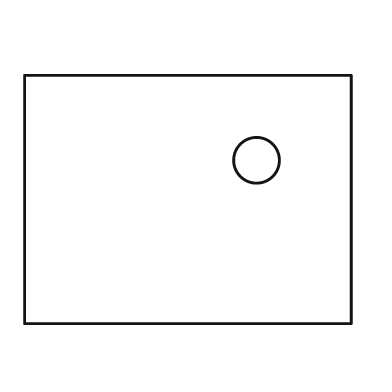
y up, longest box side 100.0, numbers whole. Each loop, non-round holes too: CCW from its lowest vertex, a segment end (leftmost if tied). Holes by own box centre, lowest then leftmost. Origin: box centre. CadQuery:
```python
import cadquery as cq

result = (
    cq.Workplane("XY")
    .moveTo(-50.0, -38.0)
    .lineTo(50.0, -38.0)
    .lineTo(50.0, 38.0)
    .lineTo(-50.0, 38.0)
    .close()
    .moveTo(21.0, 12.0)
    .circle(7.0)
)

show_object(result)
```